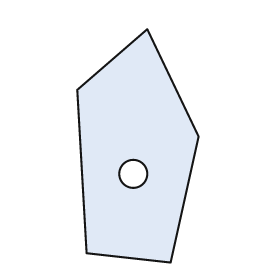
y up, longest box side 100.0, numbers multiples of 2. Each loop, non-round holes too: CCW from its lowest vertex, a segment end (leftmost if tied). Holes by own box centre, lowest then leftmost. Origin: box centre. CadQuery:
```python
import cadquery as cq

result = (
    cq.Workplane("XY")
    .moveTo(14.0, -50.0)
    .lineTo(26.0, 4.0)
    .lineTo(4.0, 50.0)
    .lineTo(-26.0, 24.0)
    .lineTo(-22.0, -46.0)
    .close()
    .moveTo(-2.0, -12.0)
    .circle(6.0)
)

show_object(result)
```